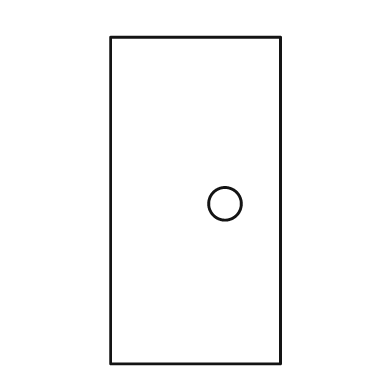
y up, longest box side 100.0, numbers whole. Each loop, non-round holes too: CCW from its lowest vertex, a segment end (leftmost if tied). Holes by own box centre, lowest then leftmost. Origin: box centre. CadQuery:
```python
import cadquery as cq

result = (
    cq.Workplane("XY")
    .moveTo(-26.0, -50.0)
    .lineTo(26.0, -50.0)
    .lineTo(26.0, 50.0)
    .lineTo(-26.0, 50.0)
    .close()
    .moveTo(9.0, -1.0)
    .circle(5.0)
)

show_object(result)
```